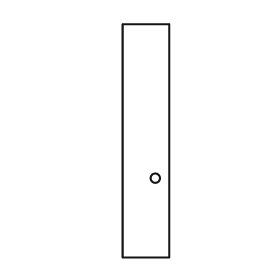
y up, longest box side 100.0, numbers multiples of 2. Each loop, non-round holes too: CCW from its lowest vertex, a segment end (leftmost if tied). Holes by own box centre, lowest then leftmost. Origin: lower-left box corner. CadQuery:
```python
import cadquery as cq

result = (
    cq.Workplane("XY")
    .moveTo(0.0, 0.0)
    .lineTo(20.0, 0.0)
    .lineTo(20.0, 100.0)
    .lineTo(0.0, 100.0)
    .close()
    .moveTo(14.0, 34.0)
    .circle(2.0)
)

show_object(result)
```